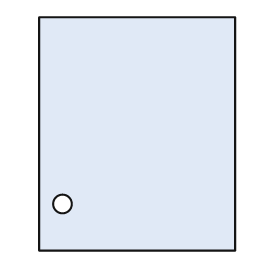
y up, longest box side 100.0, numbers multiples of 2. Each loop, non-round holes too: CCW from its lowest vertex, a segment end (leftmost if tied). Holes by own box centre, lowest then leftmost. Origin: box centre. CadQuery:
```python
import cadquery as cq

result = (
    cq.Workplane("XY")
    .moveTo(-42.0, -50.0)
    .lineTo(42.0, -50.0)
    .lineTo(42.0, 50.0)
    .lineTo(-42.0, 50.0)
    .close()
    .moveTo(-32.0, -30.0)
    .circle(4.0)
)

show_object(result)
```